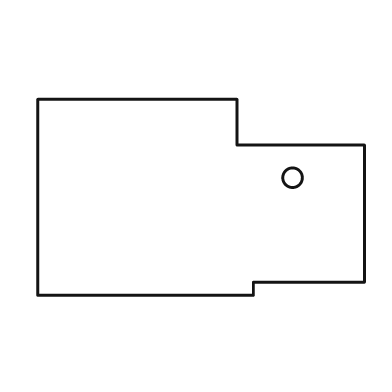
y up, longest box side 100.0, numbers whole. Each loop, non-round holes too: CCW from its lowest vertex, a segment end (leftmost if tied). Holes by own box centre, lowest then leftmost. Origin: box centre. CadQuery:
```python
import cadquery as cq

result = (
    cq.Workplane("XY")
    .moveTo(-50.0, -30.0)
    .lineTo(16.0, -30.0)
    .lineTo(16.0, -26.0)
    .lineTo(50.0, -26.0)
    .lineTo(50.0, 16.0)
    .lineTo(11.0, 16.0)
    .lineTo(11.0, 30.0)
    .lineTo(-50.0, 30.0)
    .close()
    .moveTo(28.0, 6.0)
    .circle(3.0)
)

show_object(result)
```